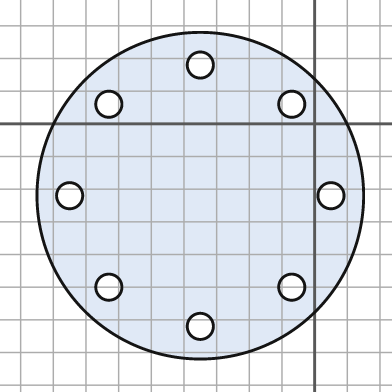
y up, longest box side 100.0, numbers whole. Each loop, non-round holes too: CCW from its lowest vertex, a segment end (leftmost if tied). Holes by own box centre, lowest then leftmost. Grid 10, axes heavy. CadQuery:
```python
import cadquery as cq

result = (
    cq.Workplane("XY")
    .moveTo(-35.0, -22.0)
    .circle(50.0)
    .moveTo(-35.0, -62.0)
    .circle(4.0)
    .moveTo(-63.0, -50.0)
    .circle(4.0)
    .moveTo(-7.0, -50.0)
    .circle(4.0)
    .moveTo(-75.0, -22.0)
    .circle(4.0)
    .moveTo(5.0, -22.0)
    .circle(4.0)
    .moveTo(-63.0, 6.0)
    .circle(4.0)
    .moveTo(-7.0, 6.0)
    .circle(4.0)
    .moveTo(-35.0, 18.0)
    .circle(4.0)
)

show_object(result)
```